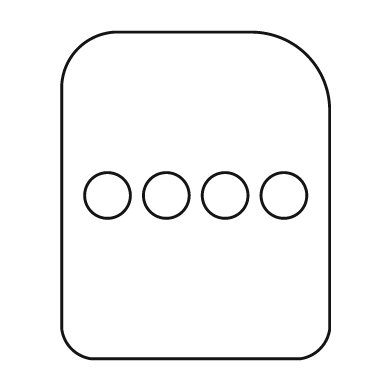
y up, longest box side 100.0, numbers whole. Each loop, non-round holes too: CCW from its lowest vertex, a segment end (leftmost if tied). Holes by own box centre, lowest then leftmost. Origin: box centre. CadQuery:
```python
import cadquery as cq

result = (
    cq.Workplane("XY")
    .moveTo(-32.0, -50.0)
    .lineTo(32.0, -50.0)
    .threePointArc((38.0, -47.0), (41.0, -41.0))
    .lineTo(41.0, 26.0)
    .threePointArc((34.0, 43.0), (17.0, 50.0))
    .lineTo(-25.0, 50.0)
    .threePointArc((-36.0, 45.0), (-41.0, 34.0))
    .lineTo(-41.0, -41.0)
    .threePointArc((-38.0, -47.0), (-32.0, -50.0))
    .close()
    .moveTo(-27.0, 0.0)
    .circle(7.0)
    .moveTo(-9.0, 0.0)
    .circle(7.0)
    .moveTo(9.0, 0.0)
    .circle(7.0)
    .moveTo(27.0, 0.0)
    .circle(7.0)
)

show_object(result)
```